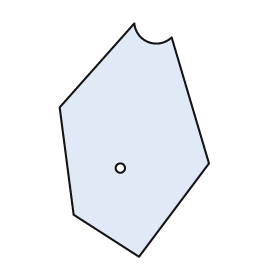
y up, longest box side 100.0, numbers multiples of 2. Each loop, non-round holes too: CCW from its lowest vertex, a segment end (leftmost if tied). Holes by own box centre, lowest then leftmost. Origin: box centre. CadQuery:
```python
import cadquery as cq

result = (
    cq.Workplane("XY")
    .moveTo(2.0, -50.0)
    .lineTo(32.0, -10.0)
    .lineTo(16.0, 44.0)
    .threePointArc((6.0, 42.0), (0.0, 50.0))
    .lineTo(-32.0, 14.0)
    .lineTo(-26.0, -32.0)
    .close()
    .moveTo(-6.0, -12.0)
    .circle(2.0)
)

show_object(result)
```